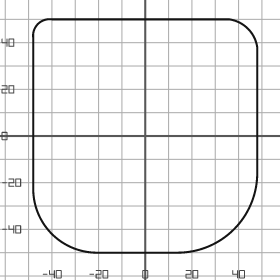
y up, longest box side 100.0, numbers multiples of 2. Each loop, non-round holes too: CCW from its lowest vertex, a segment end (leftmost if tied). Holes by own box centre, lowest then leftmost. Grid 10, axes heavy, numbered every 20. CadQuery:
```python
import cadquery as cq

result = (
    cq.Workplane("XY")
    .moveTo(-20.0, -50.0)
    .lineTo(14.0, -50.0)
    .threePointArc((38.0, -40.0), (48.0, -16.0))
    .lineTo(48.0, 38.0)
    .threePointArc((44.0, 46.0), (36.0, 50.0))
    .lineTo(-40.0, 50.0)
    .threePointArc((-46.0, 48.0), (-48.0, 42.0))
    .lineTo(-48.0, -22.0)
    .threePointArc((-40.0, -42.0), (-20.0, -50.0))
    .close()
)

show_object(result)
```